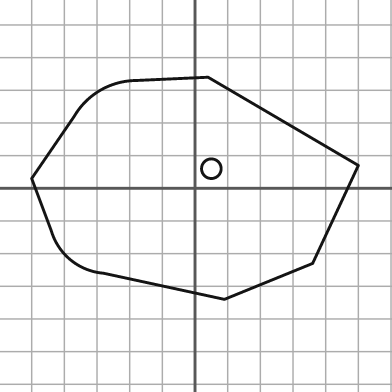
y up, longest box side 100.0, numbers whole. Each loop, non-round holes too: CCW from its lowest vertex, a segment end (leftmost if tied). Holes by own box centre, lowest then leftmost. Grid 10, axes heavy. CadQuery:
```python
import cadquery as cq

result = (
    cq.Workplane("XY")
    .moveTo(9.0, -34.0)
    .lineTo(36.0, -23.0)
    .lineTo(50.0, 7.0)
    .lineTo(4.0, 34.0)
    .lineTo(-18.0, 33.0)
    .threePointArc((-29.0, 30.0), (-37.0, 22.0))
    .lineTo(-50.0, 3.0)
    .lineTo(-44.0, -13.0)
    .threePointArc((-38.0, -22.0), (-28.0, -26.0))
    .close()
    .moveTo(5.0, 6.0)
    .circle(3.0)
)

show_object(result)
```